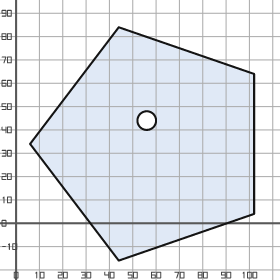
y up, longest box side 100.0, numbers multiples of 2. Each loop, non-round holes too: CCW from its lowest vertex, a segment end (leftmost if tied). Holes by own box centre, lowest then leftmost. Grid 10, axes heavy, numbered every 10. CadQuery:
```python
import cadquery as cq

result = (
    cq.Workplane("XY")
    .moveTo(44.0, -16.0)
    .lineTo(102.0, 4.0)
    .lineTo(102.0, 64.0)
    .lineTo(44.0, 84.0)
    .lineTo(6.0, 34.0)
    .close()
    .moveTo(56.0, 44.0)
    .circle(4.0)
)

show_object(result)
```